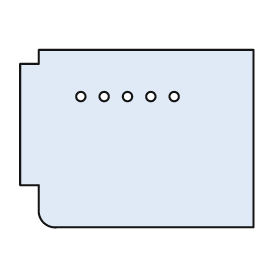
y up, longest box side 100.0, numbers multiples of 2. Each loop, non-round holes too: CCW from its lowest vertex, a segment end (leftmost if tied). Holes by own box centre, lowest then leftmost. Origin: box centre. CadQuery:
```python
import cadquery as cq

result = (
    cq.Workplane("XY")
    .moveTo(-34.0, -38.0)
    .lineTo(50.0, -38.0)
    .lineTo(50.0, 38.0)
    .lineTo(-42.0, 38.0)
    .lineTo(-42.0, 32.0)
    .lineTo(-50.0, 32.0)
    .lineTo(-50.0, -20.0)
    .lineTo(-42.0, -20.0)
    .lineTo(-42.0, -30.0)
    .threePointArc((-40.0, -36.0), (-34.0, -38.0))
    .close()
    .moveTo(-24.0, 18.0)
    .circle(2.0)
    .moveTo(-14.0, 18.0)
    .circle(2.0)
    .moveTo(-4.0, 18.0)
    .circle(2.0)
    .moveTo(6.0, 18.0)
    .circle(2.0)
    .moveTo(16.0, 18.0)
    .circle(2.0)
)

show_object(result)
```